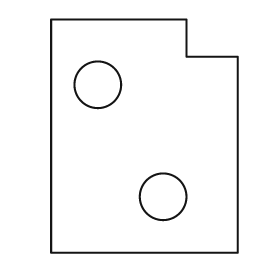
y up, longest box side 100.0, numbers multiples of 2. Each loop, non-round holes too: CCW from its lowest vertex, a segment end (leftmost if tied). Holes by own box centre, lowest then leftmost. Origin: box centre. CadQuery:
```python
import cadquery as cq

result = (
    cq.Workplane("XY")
    .moveTo(-40.0, -50.0)
    .lineTo(40.0, -50.0)
    .lineTo(40.0, 34.0)
    .lineTo(18.0, 34.0)
    .lineTo(18.0, 50.0)
    .lineTo(-40.0, 50.0)
    .close()
    .moveTo(8.0, -26.0)
    .circle(10.0)
    .moveTo(-20.0, 22.0)
    .circle(10.0)
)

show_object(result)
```